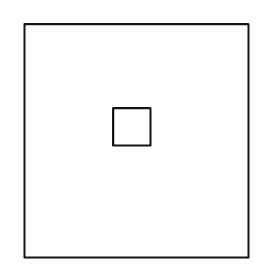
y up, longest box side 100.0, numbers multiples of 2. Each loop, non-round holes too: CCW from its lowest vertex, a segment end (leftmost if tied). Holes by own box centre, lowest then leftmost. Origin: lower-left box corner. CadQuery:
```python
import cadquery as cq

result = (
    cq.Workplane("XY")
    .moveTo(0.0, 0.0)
    .lineTo(96.0, 0.0)
    .lineTo(96.0, 100.0)
    .lineTo(0.0, 100.0)
    .close()
    .moveTo(38.0, 48.0)
    .lineTo(54.0, 48.0)
    .lineTo(54.0, 64.0)
    .lineTo(38.0, 64.0)
    .close()
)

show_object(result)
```